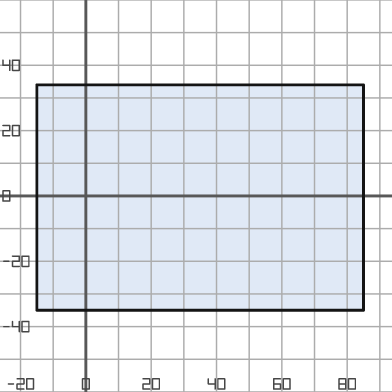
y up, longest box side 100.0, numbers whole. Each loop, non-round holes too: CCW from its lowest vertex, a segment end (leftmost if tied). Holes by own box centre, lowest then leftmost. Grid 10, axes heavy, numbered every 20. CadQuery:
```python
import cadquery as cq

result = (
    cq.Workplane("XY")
    .moveTo(-15.0, -35.0)
    .lineTo(85.0, -35.0)
    .lineTo(85.0, 34.0)
    .lineTo(-15.0, 34.0)
    .close()
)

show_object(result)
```